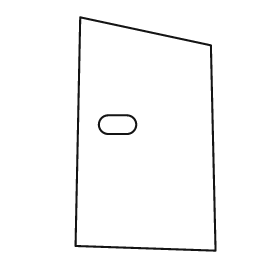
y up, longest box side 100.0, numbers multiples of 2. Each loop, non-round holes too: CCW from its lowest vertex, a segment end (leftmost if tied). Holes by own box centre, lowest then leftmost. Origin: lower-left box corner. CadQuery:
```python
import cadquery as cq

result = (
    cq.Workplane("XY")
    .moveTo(60.0, 0.0)
    .lineTo(58.0, 88.0)
    .lineTo(2.0, 100.0)
    .lineTo(0.0, 2.0)
    .close()
    .moveTo(14.0, 50.0)
    .lineTo(22.0, 50.0)
    .threePointArc((26.0, 54.0), (22.0, 58.0))
    .lineTo(14.0, 58.0)
    .threePointArc((10.0, 54.0), (14.0, 50.0))
    .close()
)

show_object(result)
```